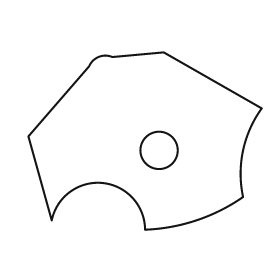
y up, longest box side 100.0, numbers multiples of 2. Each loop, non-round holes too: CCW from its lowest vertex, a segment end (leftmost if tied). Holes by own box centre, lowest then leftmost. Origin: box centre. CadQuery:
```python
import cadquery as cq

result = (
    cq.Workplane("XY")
    .moveTo(0.0, -38.0)
    .threePointArc((22.0, -34.0), (42.0, -24.0))
    .threePointArc((42.0, -4.0), (50.0, 14.0))
    .lineTo(8.0, 38.0)
    .lineTo(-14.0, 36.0)
    .threePointArc((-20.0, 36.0), (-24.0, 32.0))
    .lineTo(-50.0, 2.0)
    .lineTo(-40.0, -34.0)
    .threePointArc((-18.0, -18.0), (0.0, -38.0))
    .close()
    .moveTo(6.0, -4.0)
    .circle(8.0)
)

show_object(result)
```